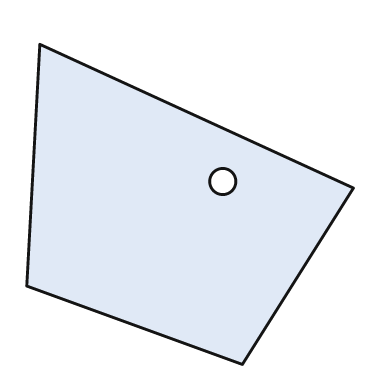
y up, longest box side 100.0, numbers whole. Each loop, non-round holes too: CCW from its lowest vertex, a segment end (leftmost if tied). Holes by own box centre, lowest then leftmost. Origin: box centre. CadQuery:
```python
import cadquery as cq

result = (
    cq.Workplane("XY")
    .moveTo(16.0, -49.0)
    .lineTo(50.0, 5.0)
    .lineTo(-46.0, 49.0)
    .lineTo(-50.0, -25.0)
    .close()
    .moveTo(10.0, 7.0)
    .circle(4.0)
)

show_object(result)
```